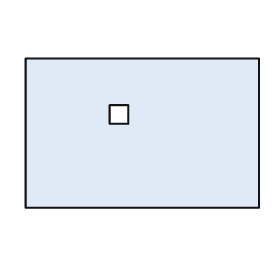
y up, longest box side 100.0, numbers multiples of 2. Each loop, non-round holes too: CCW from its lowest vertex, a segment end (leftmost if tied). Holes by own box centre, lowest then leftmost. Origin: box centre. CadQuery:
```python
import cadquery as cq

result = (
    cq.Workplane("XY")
    .moveTo(-50.0, -32.0)
    .lineTo(50.0, -32.0)
    .lineTo(50.0, 32.0)
    .lineTo(-50.0, 32.0)
    .close()
    .moveTo(-14.0, 4.0)
    .lineTo(-6.0, 4.0)
    .lineTo(-6.0, 12.0)
    .lineTo(-14.0, 12.0)
    .close()
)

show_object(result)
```